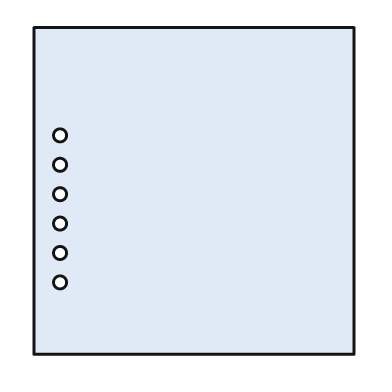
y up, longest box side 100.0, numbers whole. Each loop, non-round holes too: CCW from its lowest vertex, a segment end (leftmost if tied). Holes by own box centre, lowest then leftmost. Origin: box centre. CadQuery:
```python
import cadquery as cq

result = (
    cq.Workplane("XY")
    .moveTo(-49.0, -50.0)
    .lineTo(49.0, -50.0)
    .lineTo(49.0, 50.0)
    .lineTo(-49.0, 50.0)
    .close()
    .moveTo(-41.0, -28.0)
    .circle(2.0)
    .moveTo(-41.0, -19.0)
    .circle(2.0)
    .moveTo(-41.0, -10.0)
    .circle(2.0)
    .moveTo(-41.0, -1.0)
    .circle(2.0)
    .moveTo(-41.0, 8.0)
    .circle(2.0)
    .moveTo(-41.0, 17.0)
    .circle(2.0)
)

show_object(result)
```